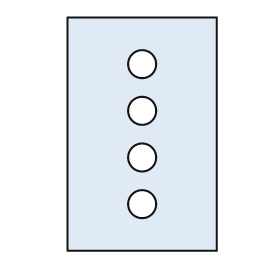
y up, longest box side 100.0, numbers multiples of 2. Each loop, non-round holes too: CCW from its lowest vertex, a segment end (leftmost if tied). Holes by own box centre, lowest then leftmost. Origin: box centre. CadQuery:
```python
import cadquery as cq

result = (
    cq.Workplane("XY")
    .moveTo(-32.0, -50.0)
    .lineTo(32.0, -50.0)
    .lineTo(32.0, 50.0)
    .lineTo(-32.0, 50.0)
    .close()
    .moveTo(0.0, -30.0)
    .circle(6.0)
    .moveTo(0.0, -10.0)
    .circle(6.0)
    .moveTo(0.0, 10.0)
    .circle(6.0)
    .moveTo(0.0, 30.0)
    .circle(6.0)
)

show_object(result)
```